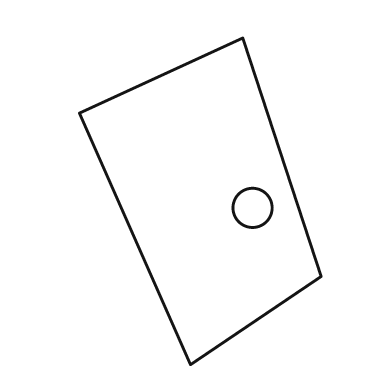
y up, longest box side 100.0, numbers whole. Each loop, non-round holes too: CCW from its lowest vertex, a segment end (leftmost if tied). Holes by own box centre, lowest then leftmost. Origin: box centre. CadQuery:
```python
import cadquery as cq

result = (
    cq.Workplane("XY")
    .moveTo(-3.0, -50.0)
    .lineTo(37.0, -23.0)
    .lineTo(13.0, 50.0)
    .lineTo(-37.0, 27.0)
    .close()
    .moveTo(16.0, -2.0)
    .circle(6.0)
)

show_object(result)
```